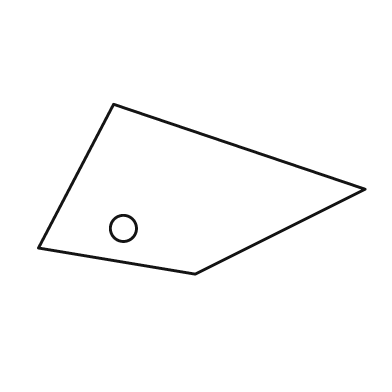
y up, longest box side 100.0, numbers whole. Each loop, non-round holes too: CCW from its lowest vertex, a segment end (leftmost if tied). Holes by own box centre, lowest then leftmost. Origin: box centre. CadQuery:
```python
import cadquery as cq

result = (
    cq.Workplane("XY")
    .moveTo(-2.0, -26.0)
    .lineTo(50.0, 0.0)
    .lineTo(-27.0, 26.0)
    .lineTo(-50.0, -18.0)
    .close()
    .moveTo(-24.0, -12.0)
    .circle(4.0)
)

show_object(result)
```